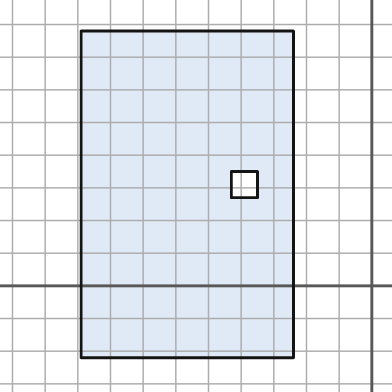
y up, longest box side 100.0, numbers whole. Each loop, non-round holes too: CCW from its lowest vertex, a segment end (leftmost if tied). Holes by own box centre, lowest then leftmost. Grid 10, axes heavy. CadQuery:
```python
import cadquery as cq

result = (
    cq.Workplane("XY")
    .moveTo(-89.0, -22.0)
    .lineTo(-24.0, -22.0)
    .lineTo(-24.0, 78.0)
    .lineTo(-89.0, 78.0)
    .close()
    .moveTo(-43.0, 27.0)
    .lineTo(-35.0, 27.0)
    .lineTo(-35.0, 35.0)
    .lineTo(-43.0, 35.0)
    .close()
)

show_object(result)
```